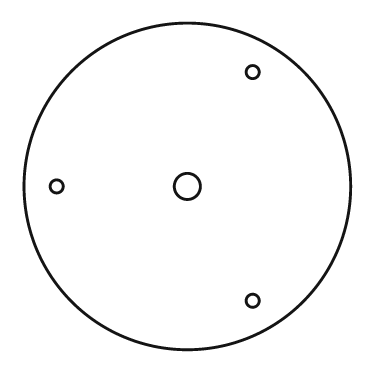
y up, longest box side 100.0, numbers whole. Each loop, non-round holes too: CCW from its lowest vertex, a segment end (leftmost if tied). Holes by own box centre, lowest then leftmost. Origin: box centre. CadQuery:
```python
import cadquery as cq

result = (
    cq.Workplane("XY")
    .moveTo(0.0, 0.0)
    .circle(50.0)
    .moveTo(20.0, -35.0)
    .circle(2.0)
    .moveTo(-40.0, 0.0)
    .circle(2.0)
    .moveTo(0.0, 0.0)
    .circle(4.0)
    .moveTo(20.0, 35.0)
    .circle(2.0)
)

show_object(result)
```